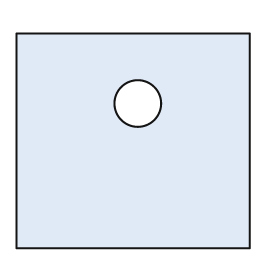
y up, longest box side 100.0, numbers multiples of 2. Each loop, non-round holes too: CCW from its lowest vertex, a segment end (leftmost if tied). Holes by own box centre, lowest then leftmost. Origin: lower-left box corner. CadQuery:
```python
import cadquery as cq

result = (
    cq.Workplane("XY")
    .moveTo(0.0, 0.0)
    .lineTo(100.0, 0.0)
    .lineTo(100.0, 92.0)
    .lineTo(0.0, 92.0)
    .close()
    .moveTo(52.0, 62.0)
    .circle(10.0)
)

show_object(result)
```